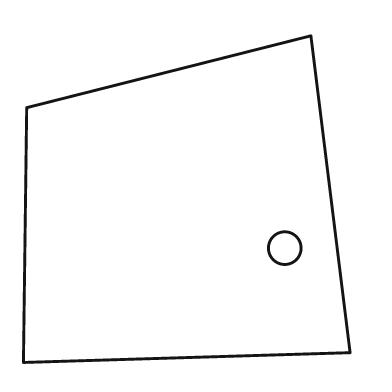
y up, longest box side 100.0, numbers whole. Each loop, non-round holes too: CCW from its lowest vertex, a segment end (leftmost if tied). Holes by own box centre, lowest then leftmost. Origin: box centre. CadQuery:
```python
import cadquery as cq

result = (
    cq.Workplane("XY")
    .moveTo(-50.0, -50.0)
    .lineTo(50.0, -47.0)
    .lineTo(38.0, 50.0)
    .lineTo(-49.0, 28.0)
    .close()
    .moveTo(30.0, -15.0)
    .circle(5.0)
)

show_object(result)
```